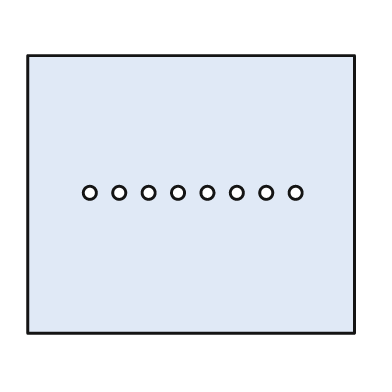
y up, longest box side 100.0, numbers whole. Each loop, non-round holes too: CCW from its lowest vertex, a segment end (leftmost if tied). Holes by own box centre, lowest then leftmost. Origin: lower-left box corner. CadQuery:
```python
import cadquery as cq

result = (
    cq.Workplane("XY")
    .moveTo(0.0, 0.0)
    .lineTo(100.0, 0.0)
    .lineTo(100.0, 85.0)
    .lineTo(0.0, 85.0)
    .close()
    .moveTo(19.0, 43.0)
    .circle(2.0)
    .moveTo(28.0, 43.0)
    .circle(2.0)
    .moveTo(37.0, 43.0)
    .circle(2.0)
    .moveTo(46.0, 43.0)
    .circle(2.0)
    .moveTo(55.0, 43.0)
    .circle(2.0)
    .moveTo(64.0, 43.0)
    .circle(2.0)
    .moveTo(73.0, 43.0)
    .circle(2.0)
    .moveTo(82.0, 43.0)
    .circle(2.0)
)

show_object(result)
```